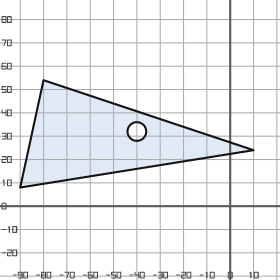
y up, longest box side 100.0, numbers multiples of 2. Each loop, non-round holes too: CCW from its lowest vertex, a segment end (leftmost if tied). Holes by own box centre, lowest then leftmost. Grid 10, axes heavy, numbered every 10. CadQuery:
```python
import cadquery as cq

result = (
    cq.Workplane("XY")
    .moveTo(-90.0, 8.0)
    .lineTo(10.0, 24.0)
    .lineTo(-80.0, 54.0)
    .close()
    .moveTo(-40.0, 32.0)
    .circle(4.0)
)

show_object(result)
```